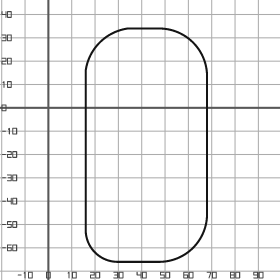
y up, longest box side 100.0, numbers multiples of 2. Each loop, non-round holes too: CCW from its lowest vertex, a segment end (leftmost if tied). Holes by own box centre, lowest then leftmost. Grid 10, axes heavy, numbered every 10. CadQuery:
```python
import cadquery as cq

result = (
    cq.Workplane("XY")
    .moveTo(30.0, -66.0)
    .lineTo(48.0, -66.0)
    .threePointArc((62.0, -60.0), (68.0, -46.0))
    .lineTo(68.0, 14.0)
    .threePointArc((62.0, 28.0), (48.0, 34.0))
    .lineTo(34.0, 34.0)
    .threePointArc((22.0, 28.0), (16.0, 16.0))
    .lineTo(16.0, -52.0)
    .threePointArc((20.0, -62.0), (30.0, -66.0))
    .close()
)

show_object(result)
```